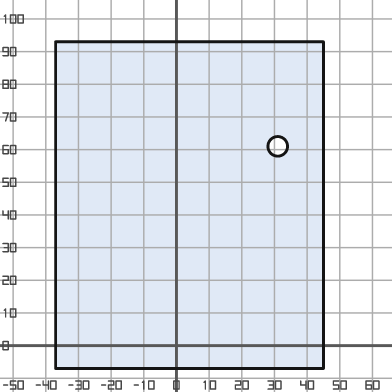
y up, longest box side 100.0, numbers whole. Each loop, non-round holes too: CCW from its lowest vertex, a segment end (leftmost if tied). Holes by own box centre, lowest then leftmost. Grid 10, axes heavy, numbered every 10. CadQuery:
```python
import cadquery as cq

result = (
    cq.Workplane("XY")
    .moveTo(-37.0, -7.0)
    .lineTo(45.0, -7.0)
    .lineTo(45.0, 93.0)
    .lineTo(-37.0, 93.0)
    .close()
    .moveTo(31.0, 61.0)
    .circle(3.0)
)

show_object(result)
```